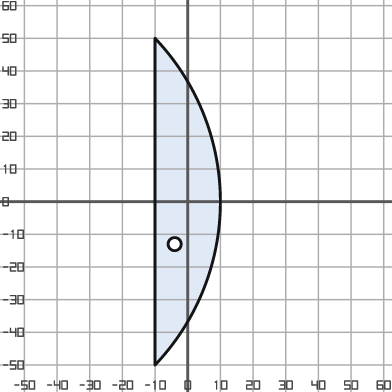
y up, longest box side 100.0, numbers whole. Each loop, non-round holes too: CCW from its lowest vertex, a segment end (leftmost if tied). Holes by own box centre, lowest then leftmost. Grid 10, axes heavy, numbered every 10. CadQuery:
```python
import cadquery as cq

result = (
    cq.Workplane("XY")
    .moveTo(-10.0, -50.0)
    .threePointArc((10.0, 0.0), (-10.0, 50.0))
    .close()
    .moveTo(-4.0, -13.0)
    .circle(2.0)
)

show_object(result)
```